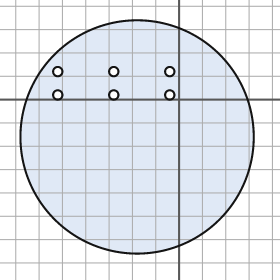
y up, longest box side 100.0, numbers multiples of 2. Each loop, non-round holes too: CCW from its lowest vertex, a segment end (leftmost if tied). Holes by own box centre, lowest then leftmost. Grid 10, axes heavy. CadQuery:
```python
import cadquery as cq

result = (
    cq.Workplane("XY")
    .moveTo(-18.0, -16.0)
    .circle(50.0)
    .moveTo(-52.0, 2.0)
    .circle(2.0)
    .moveTo(-28.0, 2.0)
    .circle(2.0)
    .moveTo(-4.0, 2.0)
    .circle(2.0)
    .moveTo(-52.0, 12.0)
    .circle(2.0)
    .moveTo(-28.0, 12.0)
    .circle(2.0)
    .moveTo(-4.0, 12.0)
    .circle(2.0)
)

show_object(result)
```